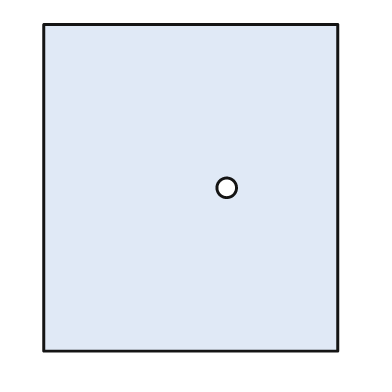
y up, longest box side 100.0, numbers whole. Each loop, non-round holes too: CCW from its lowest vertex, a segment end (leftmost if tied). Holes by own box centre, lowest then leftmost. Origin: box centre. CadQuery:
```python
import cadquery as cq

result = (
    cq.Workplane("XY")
    .moveTo(-45.0, -50.0)
    .lineTo(45.0, -50.0)
    .lineTo(45.0, 50.0)
    .lineTo(-45.0, 50.0)
    .close()
    .moveTo(11.0, 0.0)
    .circle(3.0)
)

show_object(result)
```